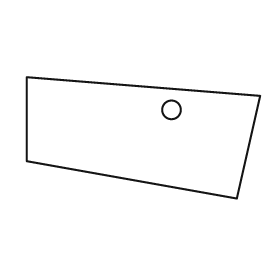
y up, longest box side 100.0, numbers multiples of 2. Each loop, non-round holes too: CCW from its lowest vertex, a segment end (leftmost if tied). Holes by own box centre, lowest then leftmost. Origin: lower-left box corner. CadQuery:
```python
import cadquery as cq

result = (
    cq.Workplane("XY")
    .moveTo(90.0, 0.0)
    .lineTo(100.0, 44.0)
    .lineTo(0.0, 52.0)
    .lineTo(0.0, 16.0)
    .close()
    .moveTo(62.0, 38.0)
    .circle(4.0)
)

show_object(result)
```